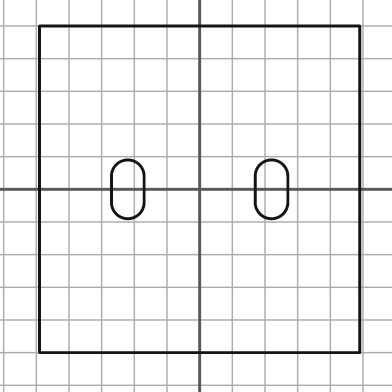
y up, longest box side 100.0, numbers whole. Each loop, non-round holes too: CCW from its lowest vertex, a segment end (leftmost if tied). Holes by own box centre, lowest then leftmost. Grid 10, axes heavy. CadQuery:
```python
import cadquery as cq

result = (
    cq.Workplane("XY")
    .moveTo(-49.0, -50.0)
    .lineTo(49.0, -50.0)
    .lineTo(49.0, 50.0)
    .lineTo(-49.0, 50.0)
    .close()
    .moveTo(-27.0, -4.0)
    .threePointArc((-22.0, -9.0), (-17.0, -4.0))
    .lineTo(-17.0, 4.0)
    .threePointArc((-22.0, 9.0), (-27.0, 4.0))
    .close()
    .moveTo(17.0, -4.0)
    .threePointArc((22.0, -9.0), (27.0, -4.0))
    .lineTo(27.0, 4.0)
    .threePointArc((22.0, 9.0), (17.0, 4.0))
    .close()
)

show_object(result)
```